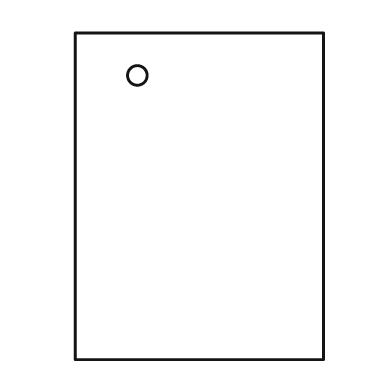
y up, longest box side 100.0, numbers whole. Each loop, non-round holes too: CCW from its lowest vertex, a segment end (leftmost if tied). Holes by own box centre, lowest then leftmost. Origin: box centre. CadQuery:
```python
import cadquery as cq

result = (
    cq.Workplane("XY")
    .moveTo(-38.0, -50.0)
    .lineTo(38.0, -50.0)
    .lineTo(38.0, 50.0)
    .lineTo(-38.0, 50.0)
    .close()
    .moveTo(-19.0, 37.0)
    .circle(3.0)
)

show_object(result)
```